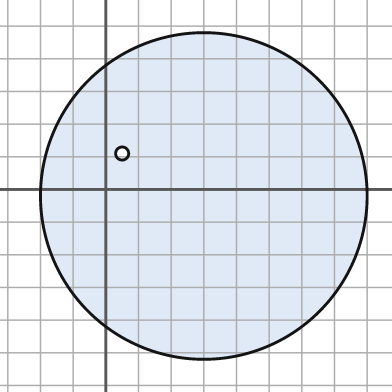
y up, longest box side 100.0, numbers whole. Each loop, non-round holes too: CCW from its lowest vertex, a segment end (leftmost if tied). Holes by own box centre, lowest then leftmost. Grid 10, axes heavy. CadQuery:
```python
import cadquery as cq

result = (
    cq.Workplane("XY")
    .moveTo(30.0, -2.0)
    .circle(50.0)
    .moveTo(5.0, 11.0)
    .circle(2.0)
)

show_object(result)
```